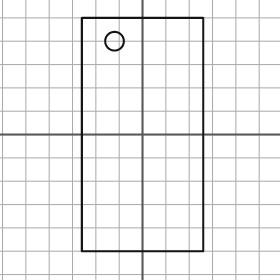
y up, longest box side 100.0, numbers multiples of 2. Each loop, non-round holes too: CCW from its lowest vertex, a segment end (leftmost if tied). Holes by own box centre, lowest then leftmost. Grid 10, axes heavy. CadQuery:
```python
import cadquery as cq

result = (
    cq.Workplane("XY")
    .moveTo(-26.0, -50.0)
    .lineTo(26.0, -50.0)
    .lineTo(26.0, 50.0)
    .lineTo(-26.0, 50.0)
    .close()
    .moveTo(-12.0, 40.0)
    .circle(4.0)
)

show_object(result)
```